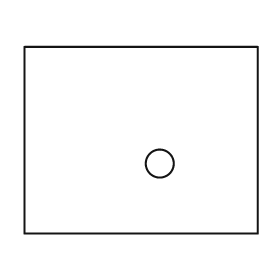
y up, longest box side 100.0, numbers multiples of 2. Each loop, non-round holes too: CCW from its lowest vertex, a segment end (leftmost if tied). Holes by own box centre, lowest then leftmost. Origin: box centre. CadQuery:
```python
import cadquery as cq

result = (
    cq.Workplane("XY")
    .moveTo(-50.0, -40.0)
    .lineTo(50.0, -40.0)
    .lineTo(50.0, 40.0)
    .lineTo(-50.0, 40.0)
    .close()
    .moveTo(8.0, -10.0)
    .circle(6.0)
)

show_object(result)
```